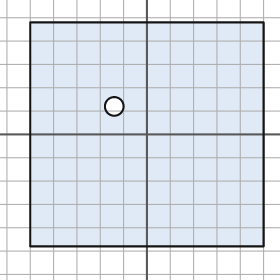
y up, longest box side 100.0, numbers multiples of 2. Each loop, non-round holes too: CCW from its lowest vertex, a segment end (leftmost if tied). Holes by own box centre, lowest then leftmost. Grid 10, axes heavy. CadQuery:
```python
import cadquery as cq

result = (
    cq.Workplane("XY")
    .moveTo(-50.0, -48.0)
    .lineTo(50.0, -48.0)
    .lineTo(50.0, 48.0)
    .lineTo(-50.0, 48.0)
    .close()
    .moveTo(-14.0, 12.0)
    .circle(4.0)
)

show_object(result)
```